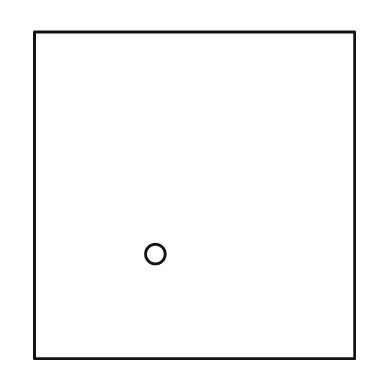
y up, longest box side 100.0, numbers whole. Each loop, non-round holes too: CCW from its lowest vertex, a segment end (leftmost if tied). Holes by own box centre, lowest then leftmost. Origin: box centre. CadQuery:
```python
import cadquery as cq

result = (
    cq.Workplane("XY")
    .moveTo(-49.0, -50.0)
    .lineTo(49.0, -50.0)
    .lineTo(49.0, 50.0)
    .lineTo(-49.0, 50.0)
    .close()
    .moveTo(-12.0, -18.0)
    .circle(3.0)
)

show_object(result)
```